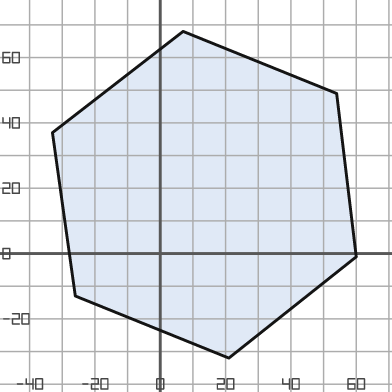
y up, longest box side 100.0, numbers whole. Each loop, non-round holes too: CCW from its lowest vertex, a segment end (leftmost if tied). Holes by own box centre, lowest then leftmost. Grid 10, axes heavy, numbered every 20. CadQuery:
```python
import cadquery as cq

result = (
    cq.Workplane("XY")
    .moveTo(21.0, -32.0)
    .lineTo(60.0, -1.0)
    .lineTo(54.0, 49.0)
    .lineTo(7.0, 68.0)
    .lineTo(-33.0, 37.0)
    .lineTo(-26.0, -13.0)
    .close()
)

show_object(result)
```